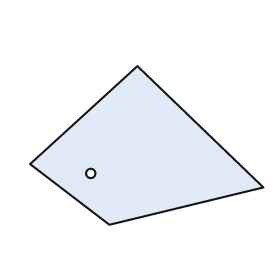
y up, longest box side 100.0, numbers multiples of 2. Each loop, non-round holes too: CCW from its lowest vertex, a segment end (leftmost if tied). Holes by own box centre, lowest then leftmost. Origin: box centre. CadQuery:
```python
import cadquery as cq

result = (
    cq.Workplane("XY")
    .moveTo(-16.0, -34.0)
    .lineTo(50.0, -18.0)
    .lineTo(-4.0, 34.0)
    .lineTo(-50.0, -8.0)
    .close()
    .moveTo(-24.0, -12.0)
    .circle(2.0)
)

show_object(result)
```